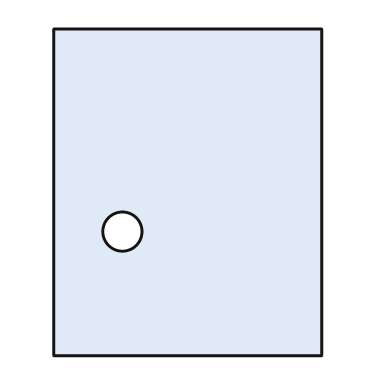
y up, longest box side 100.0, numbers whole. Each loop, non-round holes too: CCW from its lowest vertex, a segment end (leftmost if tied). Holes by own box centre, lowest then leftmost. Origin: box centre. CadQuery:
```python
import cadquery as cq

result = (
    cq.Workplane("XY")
    .moveTo(-41.0, -50.0)
    .lineTo(41.0, -50.0)
    .lineTo(41.0, 50.0)
    .lineTo(-41.0, 50.0)
    .close()
    .moveTo(-20.0, -12.0)
    .circle(6.0)
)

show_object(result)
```